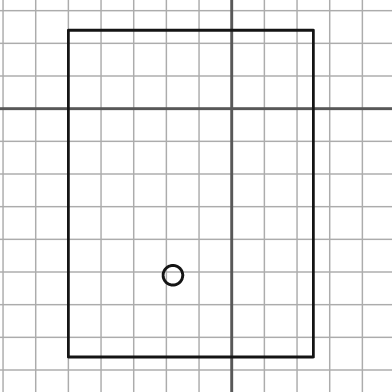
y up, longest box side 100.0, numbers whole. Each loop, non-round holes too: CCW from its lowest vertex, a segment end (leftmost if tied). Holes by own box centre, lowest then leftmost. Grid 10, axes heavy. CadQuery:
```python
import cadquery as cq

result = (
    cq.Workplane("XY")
    .moveTo(-50.0, -76.0)
    .lineTo(25.0, -76.0)
    .lineTo(25.0, 24.0)
    .lineTo(-50.0, 24.0)
    .close()
    .moveTo(-18.0, -51.0)
    .circle(3.0)
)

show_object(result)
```